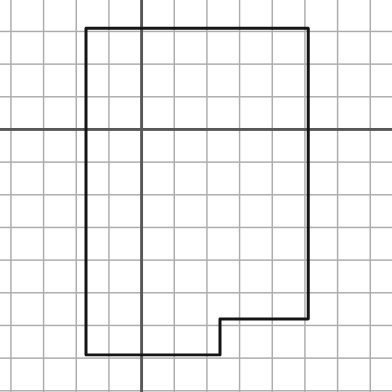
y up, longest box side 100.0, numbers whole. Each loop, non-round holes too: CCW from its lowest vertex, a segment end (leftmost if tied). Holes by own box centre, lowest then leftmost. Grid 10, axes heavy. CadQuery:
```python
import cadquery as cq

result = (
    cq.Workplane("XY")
    .moveTo(-17.0, -69.0)
    .lineTo(24.0, -69.0)
    .lineTo(24.0, -58.0)
    .lineTo(51.0, -58.0)
    .lineTo(51.0, 31.0)
    .lineTo(-17.0, 31.0)
    .close()
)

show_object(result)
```